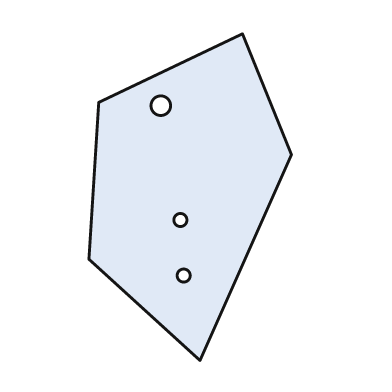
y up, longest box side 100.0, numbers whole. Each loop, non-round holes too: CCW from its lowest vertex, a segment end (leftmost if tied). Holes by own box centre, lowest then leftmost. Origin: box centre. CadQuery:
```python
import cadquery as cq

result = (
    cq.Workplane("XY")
    .moveTo(3.0, -50.0)
    .lineTo(31.0, 13.0)
    .lineTo(16.0, 50.0)
    .lineTo(-28.0, 29.0)
    .lineTo(-31.0, -19.0)
    .close()
    .moveTo(-2.0, -24.0)
    .circle(2.0)
    .moveTo(-3.0, -7.0)
    .circle(2.0)
    .moveTo(-9.0, 28.0)
    .circle(3.0)
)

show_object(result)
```